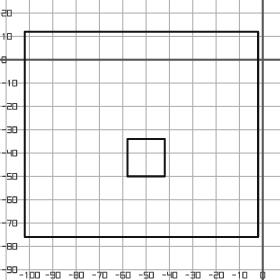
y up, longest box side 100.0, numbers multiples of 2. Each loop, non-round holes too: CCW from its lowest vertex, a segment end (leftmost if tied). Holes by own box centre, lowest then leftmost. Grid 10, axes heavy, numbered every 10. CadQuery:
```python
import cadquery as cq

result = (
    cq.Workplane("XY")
    .moveTo(-102.0, -76.0)
    .lineTo(-2.0, -76.0)
    .lineTo(-2.0, 12.0)
    .lineTo(-102.0, 12.0)
    .close()
    .moveTo(-58.0, -50.0)
    .lineTo(-42.0, -50.0)
    .lineTo(-42.0, -34.0)
    .lineTo(-58.0, -34.0)
    .close()
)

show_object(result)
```